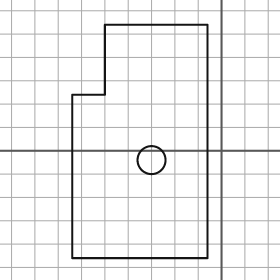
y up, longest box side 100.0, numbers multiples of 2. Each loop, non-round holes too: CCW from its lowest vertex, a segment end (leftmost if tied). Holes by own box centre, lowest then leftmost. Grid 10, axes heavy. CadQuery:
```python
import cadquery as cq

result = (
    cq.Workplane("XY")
    .moveTo(-64.0, -46.0)
    .lineTo(-6.0, -46.0)
    .lineTo(-6.0, 54.0)
    .lineTo(-50.0, 54.0)
    .lineTo(-50.0, 24.0)
    .lineTo(-64.0, 24.0)
    .close()
    .moveTo(-30.0, -4.0)
    .circle(6.0)
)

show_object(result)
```